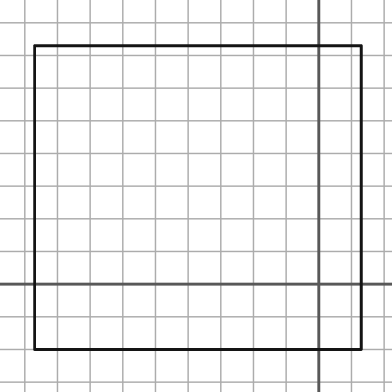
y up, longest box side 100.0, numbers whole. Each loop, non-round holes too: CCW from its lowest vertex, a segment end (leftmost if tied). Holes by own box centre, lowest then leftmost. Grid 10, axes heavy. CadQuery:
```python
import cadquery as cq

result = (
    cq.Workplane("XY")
    .moveTo(-87.0, -20.0)
    .lineTo(13.0, -20.0)
    .lineTo(13.0, 73.0)
    .lineTo(-87.0, 73.0)
    .close()
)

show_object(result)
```